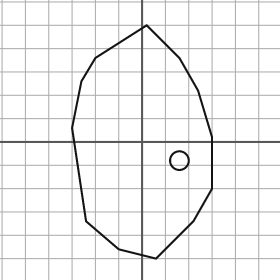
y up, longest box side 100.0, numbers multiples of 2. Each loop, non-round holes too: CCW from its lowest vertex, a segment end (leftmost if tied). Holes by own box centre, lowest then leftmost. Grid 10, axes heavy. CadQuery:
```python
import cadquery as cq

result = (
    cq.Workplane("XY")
    .moveTo(6.0, -50.0)
    .lineTo(22.0, -34.0)
    .lineTo(30.0, -20.0)
    .lineTo(30.0, 2.0)
    .lineTo(24.0, 22.0)
    .lineTo(16.0, 36.0)
    .lineTo(2.0, 50.0)
    .lineTo(-20.0, 36.0)
    .lineTo(-26.0, 26.0)
    .lineTo(-30.0, 6.0)
    .lineTo(-24.0, -34.0)
    .lineTo(-10.0, -46.0)
    .close()
    .moveTo(16.0, -8.0)
    .circle(4.0)
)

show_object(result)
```